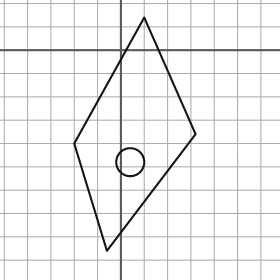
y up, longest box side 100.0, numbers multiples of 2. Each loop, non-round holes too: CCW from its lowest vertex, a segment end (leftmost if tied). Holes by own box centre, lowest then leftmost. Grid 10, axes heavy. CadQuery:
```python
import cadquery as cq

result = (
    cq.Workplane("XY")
    .moveTo(-6.0, -86.0)
    .lineTo(32.0, -36.0)
    .lineTo(10.0, 14.0)
    .lineTo(-20.0, -40.0)
    .close()
    .moveTo(4.0, -48.0)
    .circle(6.0)
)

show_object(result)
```